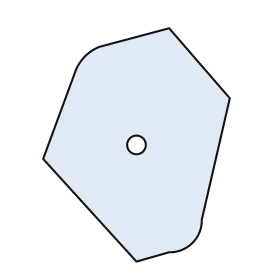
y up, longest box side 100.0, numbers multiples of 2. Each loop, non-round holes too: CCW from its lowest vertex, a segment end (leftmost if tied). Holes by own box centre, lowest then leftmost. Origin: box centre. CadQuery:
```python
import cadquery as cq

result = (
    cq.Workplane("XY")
    .moveTo(0.0, -50.0)
    .lineTo(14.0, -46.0)
    .threePointArc((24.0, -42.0), (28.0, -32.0))
    .lineTo(40.0, 20.0)
    .lineTo(14.0, 50.0)
    .lineTo(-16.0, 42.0)
    .threePointArc((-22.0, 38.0), (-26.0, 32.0))
    .lineTo(-40.0, -6.0)
    .close()
    .moveTo(0.0, 0.0)
    .circle(4.0)
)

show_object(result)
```